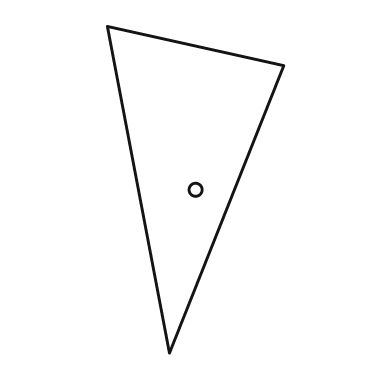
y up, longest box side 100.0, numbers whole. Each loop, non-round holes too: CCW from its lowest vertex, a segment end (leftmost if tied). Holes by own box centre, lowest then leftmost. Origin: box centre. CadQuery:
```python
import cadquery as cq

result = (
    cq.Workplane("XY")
    .moveTo(-8.0, -50.0)
    .lineTo(27.0, 38.0)
    .lineTo(-27.0, 50.0)
    .close()
    .moveTo(0.0, 0.0)
    .circle(2.0)
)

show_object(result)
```